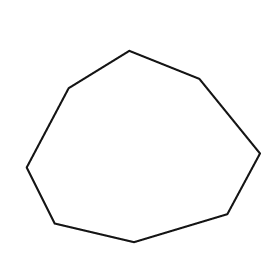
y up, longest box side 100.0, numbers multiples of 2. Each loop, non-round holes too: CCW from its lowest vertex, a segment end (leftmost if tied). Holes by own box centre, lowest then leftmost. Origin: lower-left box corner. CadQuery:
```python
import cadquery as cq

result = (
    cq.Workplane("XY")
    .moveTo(46.0, 0.0)
    .lineTo(86.0, 12.0)
    .lineTo(100.0, 38.0)
    .lineTo(74.0, 70.0)
    .lineTo(44.0, 82.0)
    .lineTo(18.0, 66.0)
    .lineTo(0.0, 32.0)
    .lineTo(12.0, 8.0)
    .close()
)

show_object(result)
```